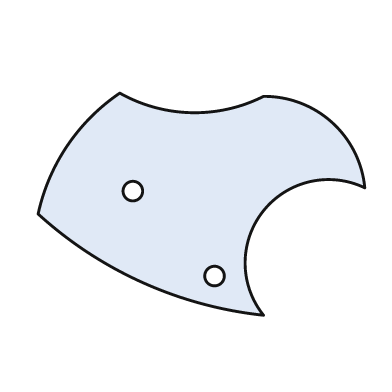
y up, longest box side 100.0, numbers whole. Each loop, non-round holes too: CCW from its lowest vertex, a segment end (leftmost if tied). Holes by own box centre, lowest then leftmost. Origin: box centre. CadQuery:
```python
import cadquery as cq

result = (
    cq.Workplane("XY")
    .moveTo(19.0, -34.0)
    .threePointArc((19.0, -2.0), (50.0, 5.0))
    .threePointArc((40.0, 25.0), (19.0, 33.0))
    .threePointArc((-3.0, 28.0), (-25.0, 34.0))
    .threePointArc((-41.0, 18.0), (-50.0, -3.0))
    .threePointArc((-18.0, -24.0), (19.0, -34.0))
    .close()
    .moveTo(4.0, -22.0)
    .circle(3.0)
    .moveTo(-21.0, 4.0)
    .circle(3.0)
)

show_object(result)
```